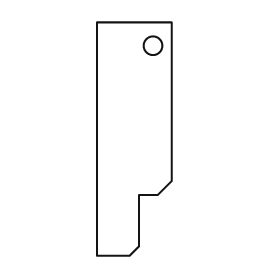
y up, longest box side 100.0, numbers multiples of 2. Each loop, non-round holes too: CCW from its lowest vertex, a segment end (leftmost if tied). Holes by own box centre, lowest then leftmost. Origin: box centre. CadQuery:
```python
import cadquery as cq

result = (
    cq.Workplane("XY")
    .moveTo(-16.0, -50.0)
    .lineTo(-2.0, -50.0)
    .lineTo(2.0, -46.0)
    .lineTo(2.0, -24.0)
    .lineTo(10.0, -24.0)
    .lineTo(16.0, -18.0)
    .lineTo(16.0, 50.0)
    .lineTo(-16.0, 50.0)
    .close()
    .moveTo(8.0, 40.0)
    .circle(4.0)
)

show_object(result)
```